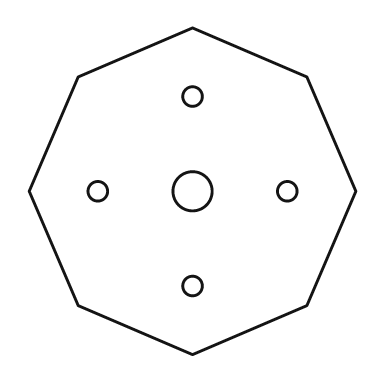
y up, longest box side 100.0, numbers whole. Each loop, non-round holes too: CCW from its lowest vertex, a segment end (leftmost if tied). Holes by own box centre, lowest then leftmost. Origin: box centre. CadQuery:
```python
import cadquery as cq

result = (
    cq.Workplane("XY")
    .moveTo(0.0, -50.0)
    .lineTo(35.0, -35.0)
    .lineTo(50.0, 0.0)
    .lineTo(35.0, 35.0)
    .lineTo(0.0, 50.0)
    .lineTo(-35.0, 35.0)
    .lineTo(-50.0, 0.0)
    .lineTo(-35.0, -35.0)
    .close()
    .moveTo(0.0, -29.0)
    .circle(3.0)
    .moveTo(-29.0, 0.0)
    .circle(3.0)
    .moveTo(0.0, 0.0)
    .circle(6.0)
    .moveTo(29.0, 0.0)
    .circle(3.0)
    .moveTo(0.0, 29.0)
    .circle(3.0)
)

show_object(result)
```